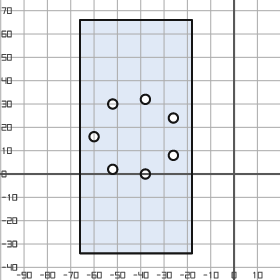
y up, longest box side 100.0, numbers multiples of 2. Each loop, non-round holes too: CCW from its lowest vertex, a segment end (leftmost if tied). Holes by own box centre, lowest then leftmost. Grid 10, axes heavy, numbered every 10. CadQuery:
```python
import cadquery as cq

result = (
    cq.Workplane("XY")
    .moveTo(-66.0, -34.0)
    .lineTo(-18.0, -34.0)
    .lineTo(-18.0, 66.0)
    .lineTo(-66.0, 66.0)
    .close()
    .moveTo(-38.0, 0.0)
    .circle(2.0)
    .moveTo(-52.0, 2.0)
    .circle(2.0)
    .moveTo(-26.0, 8.0)
    .circle(2.0)
    .moveTo(-60.0, 16.0)
    .circle(2.0)
    .moveTo(-26.0, 24.0)
    .circle(2.0)
    .moveTo(-52.0, 30.0)
    .circle(2.0)
    .moveTo(-38.0, 32.0)
    .circle(2.0)
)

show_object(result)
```